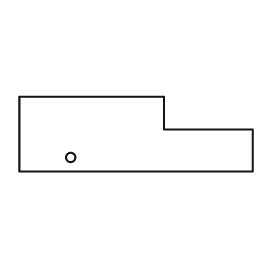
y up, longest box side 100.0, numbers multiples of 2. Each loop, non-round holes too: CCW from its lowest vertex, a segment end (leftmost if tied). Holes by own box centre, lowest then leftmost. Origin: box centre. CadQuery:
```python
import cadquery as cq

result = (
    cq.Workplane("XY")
    .moveTo(-50.0, -16.0)
    .lineTo(50.0, -16.0)
    .lineTo(50.0, 2.0)
    .lineTo(12.0, 2.0)
    .lineTo(12.0, 16.0)
    .lineTo(-50.0, 16.0)
    .close()
    .moveTo(-28.0, -10.0)
    .circle(2.0)
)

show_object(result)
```